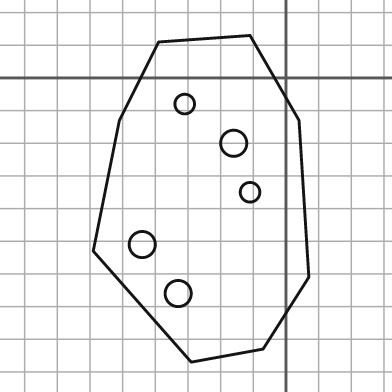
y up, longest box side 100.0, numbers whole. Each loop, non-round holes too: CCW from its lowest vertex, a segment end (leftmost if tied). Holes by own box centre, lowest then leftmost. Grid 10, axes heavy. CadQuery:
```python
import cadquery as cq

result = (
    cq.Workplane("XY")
    .moveTo(-29.0, -87.0)
    .lineTo(-7.0, -83.0)
    .lineTo(7.0, -61.0)
    .lineTo(4.0, -13.0)
    .lineTo(-11.0, 13.0)
    .lineTo(-39.0, 11.0)
    .lineTo(-51.0, -13.0)
    .lineTo(-59.0, -53.0)
    .close()
    .moveTo(-33.0, -66.0)
    .circle(4.0)
    .moveTo(-44.0, -51.0)
    .circle(4.0)
    .moveTo(-11.0, -35.0)
    .circle(3.0)
    .moveTo(-16.0, -20.0)
    .circle(4.0)
    .moveTo(-31.0, -8.0)
    .circle(3.0)
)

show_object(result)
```